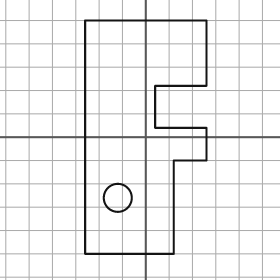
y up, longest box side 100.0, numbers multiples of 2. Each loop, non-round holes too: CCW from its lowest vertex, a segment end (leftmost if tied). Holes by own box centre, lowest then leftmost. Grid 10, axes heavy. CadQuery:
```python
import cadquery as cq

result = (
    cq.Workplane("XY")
    .moveTo(-26.0, -50.0)
    .lineTo(12.0, -50.0)
    .lineTo(12.0, -10.0)
    .lineTo(26.0, -10.0)
    .lineTo(26.0, 4.0)
    .lineTo(4.0, 4.0)
    .lineTo(4.0, 22.0)
    .lineTo(26.0, 22.0)
    .lineTo(26.0, 50.0)
    .lineTo(-26.0, 50.0)
    .close()
    .moveTo(-12.0, -26.0)
    .circle(6.0)
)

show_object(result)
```